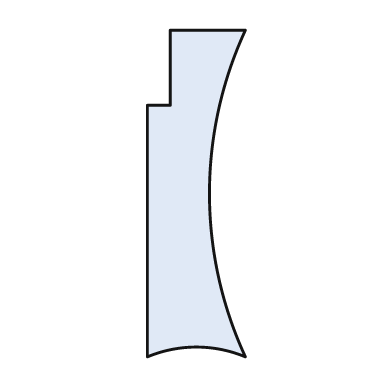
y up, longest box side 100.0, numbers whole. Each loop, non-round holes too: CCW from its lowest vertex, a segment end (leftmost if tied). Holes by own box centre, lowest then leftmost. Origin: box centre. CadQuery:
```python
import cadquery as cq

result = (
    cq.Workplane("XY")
    .moveTo(-15.0, -50.0)
    .threePointArc((0.0, -47.0), (15.0, -50.0))
    .threePointArc((4.0, 0.0), (15.0, 50.0))
    .lineTo(-8.0, 50.0)
    .lineTo(-8.0, 27.0)
    .lineTo(-15.0, 27.0)
    .close()
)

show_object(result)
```